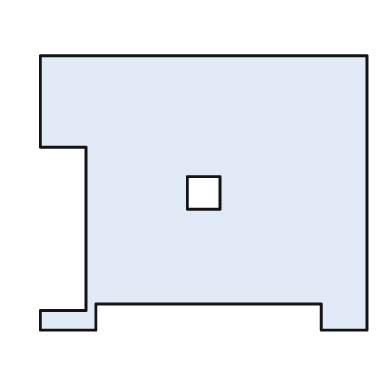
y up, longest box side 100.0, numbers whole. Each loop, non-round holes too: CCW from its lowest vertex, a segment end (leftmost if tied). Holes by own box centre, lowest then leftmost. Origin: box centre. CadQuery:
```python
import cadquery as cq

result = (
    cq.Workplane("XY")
    .moveTo(-50.0, -42.0)
    .lineTo(-33.0, -42.0)
    .lineTo(-33.0, -34.0)
    .lineTo(36.0, -34.0)
    .lineTo(36.0, -42.0)
    .lineTo(50.0, -42.0)
    .lineTo(50.0, 42.0)
    .lineTo(-50.0, 42.0)
    .lineTo(-50.0, 14.0)
    .lineTo(-36.0, 14.0)
    .lineTo(-36.0, -36.0)
    .lineTo(-50.0, -36.0)
    .close()
    .moveTo(-5.0, -5.0)
    .lineTo(5.0, -5.0)
    .lineTo(5.0, 5.0)
    .lineTo(-5.0, 5.0)
    .close()
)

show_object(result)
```